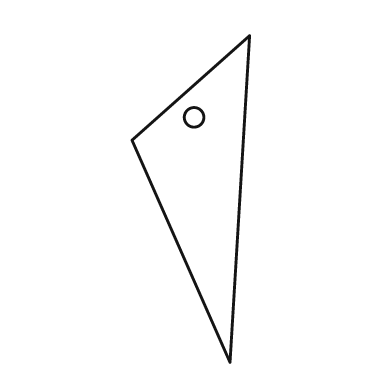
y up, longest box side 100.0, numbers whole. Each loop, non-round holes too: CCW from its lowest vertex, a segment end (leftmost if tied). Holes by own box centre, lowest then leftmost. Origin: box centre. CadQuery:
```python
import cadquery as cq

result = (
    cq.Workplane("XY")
    .moveTo(12.0, -50.0)
    .lineTo(18.0, 50.0)
    .lineTo(-18.0, 18.0)
    .close()
    .moveTo(1.0, 25.0)
    .circle(3.0)
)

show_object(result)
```